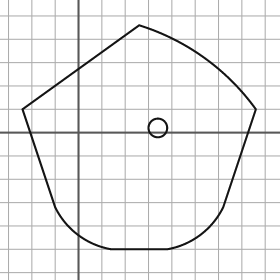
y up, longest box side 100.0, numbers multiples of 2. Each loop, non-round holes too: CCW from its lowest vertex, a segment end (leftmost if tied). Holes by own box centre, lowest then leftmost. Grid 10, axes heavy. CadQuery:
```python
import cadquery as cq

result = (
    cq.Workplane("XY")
    .moveTo(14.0, -50.0)
    .lineTo(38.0, -50.0)
    .threePointArc((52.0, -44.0), (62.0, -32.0))
    .lineTo(76.0, 10.0)
    .threePointArc((54.0, 32.0), (26.0, 46.0))
    .lineTo(-24.0, 10.0)
    .lineTo(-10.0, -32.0)
    .threePointArc((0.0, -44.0), (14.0, -50.0))
    .close()
    .moveTo(34.0, 2.0)
    .circle(4.0)
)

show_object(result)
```